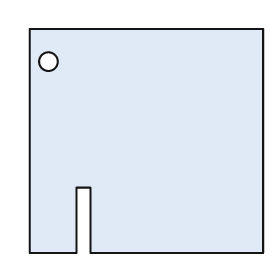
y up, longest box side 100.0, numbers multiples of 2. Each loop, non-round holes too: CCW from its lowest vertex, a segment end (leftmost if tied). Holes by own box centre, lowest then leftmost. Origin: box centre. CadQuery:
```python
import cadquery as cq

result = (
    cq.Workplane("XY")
    .moveTo(-50.0, -48.0)
    .lineTo(-30.0, -48.0)
    .lineTo(-30.0, -20.0)
    .lineTo(-24.0, -20.0)
    .lineTo(-24.0, -48.0)
    .lineTo(50.0, -48.0)
    .lineTo(50.0, 48.0)
    .lineTo(-50.0, 48.0)
    .close()
    .moveTo(-42.0, 34.0)
    .circle(4.0)
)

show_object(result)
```